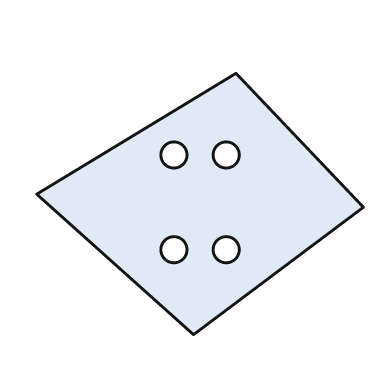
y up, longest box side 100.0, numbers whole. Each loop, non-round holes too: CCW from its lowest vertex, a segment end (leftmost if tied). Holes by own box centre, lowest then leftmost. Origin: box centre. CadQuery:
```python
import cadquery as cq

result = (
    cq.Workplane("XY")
    .moveTo(-2.0, -40.0)
    .lineTo(50.0, -1.0)
    .lineTo(11.0, 40.0)
    .lineTo(-50.0, 3.0)
    .close()
    .moveTo(-8.0, -14.0)
    .circle(4.0)
    .moveTo(8.0, -14.0)
    .circle(4.0)
    .moveTo(-8.0, 15.0)
    .circle(4.0)
    .moveTo(8.0, 15.0)
    .circle(4.0)
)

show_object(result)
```